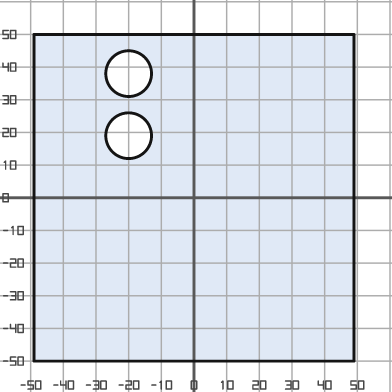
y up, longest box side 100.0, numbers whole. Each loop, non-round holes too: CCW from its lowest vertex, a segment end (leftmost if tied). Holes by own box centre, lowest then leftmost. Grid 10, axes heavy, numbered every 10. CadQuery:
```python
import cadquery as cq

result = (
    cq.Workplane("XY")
    .moveTo(-49.0, -50.0)
    .lineTo(49.0, -50.0)
    .lineTo(49.0, 50.0)
    .lineTo(-49.0, 50.0)
    .close()
    .moveTo(-20.0, 19.0)
    .circle(7.0)
    .moveTo(-20.0, 38.0)
    .circle(7.0)
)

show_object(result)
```